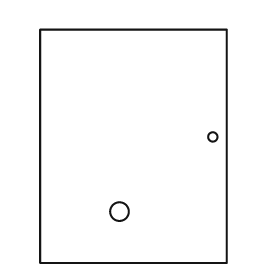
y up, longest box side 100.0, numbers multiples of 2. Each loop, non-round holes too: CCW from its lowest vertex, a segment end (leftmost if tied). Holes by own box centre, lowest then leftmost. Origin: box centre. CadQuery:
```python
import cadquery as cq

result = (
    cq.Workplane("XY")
    .moveTo(-40.0, -50.0)
    .lineTo(40.0, -50.0)
    .lineTo(40.0, 50.0)
    .lineTo(-40.0, 50.0)
    .close()
    .moveTo(-6.0, -28.0)
    .circle(4.0)
    .moveTo(34.0, 4.0)
    .circle(2.0)
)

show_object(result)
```